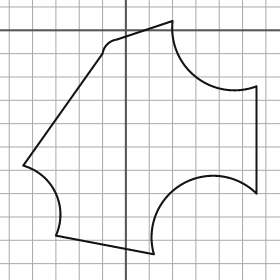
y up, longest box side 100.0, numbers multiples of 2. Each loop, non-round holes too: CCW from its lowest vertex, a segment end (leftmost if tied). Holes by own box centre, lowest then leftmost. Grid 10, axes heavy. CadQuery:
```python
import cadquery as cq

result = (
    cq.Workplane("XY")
    .moveTo(12.0, -96.0)
    .threePointArc((24.0, -66.0), (56.0, -70.0))
    .lineTo(56.0, -24.0)
    .threePointArc((30.0, -20.0), (20.0, 4.0))
    .lineTo(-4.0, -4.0)
    .threePointArc((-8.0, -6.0), (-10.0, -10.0))
    .lineTo(-44.0, -58.0)
    .threePointArc((-30.0, -70.0), (-30.0, -88.0))
    .close()
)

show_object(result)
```